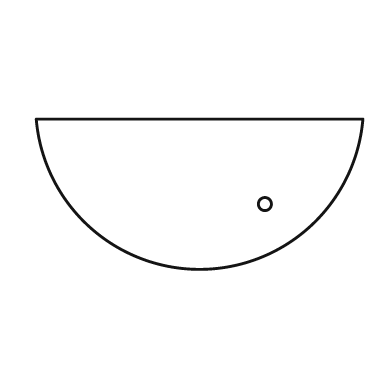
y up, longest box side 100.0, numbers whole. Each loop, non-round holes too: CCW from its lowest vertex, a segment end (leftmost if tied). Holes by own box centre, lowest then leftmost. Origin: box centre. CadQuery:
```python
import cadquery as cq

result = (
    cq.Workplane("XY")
    .moveTo(-50.0, 23.0)
    .threePointArc((0.0, -23.0), (50.0, 23.0))
    .close()
    .moveTo(20.0, -3.0)
    .circle(2.0)
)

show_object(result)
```